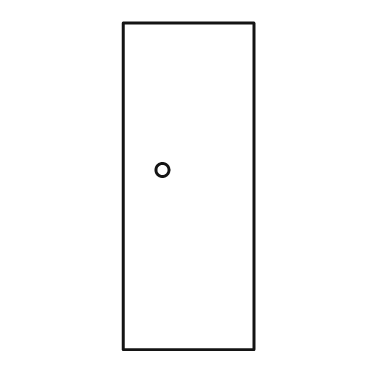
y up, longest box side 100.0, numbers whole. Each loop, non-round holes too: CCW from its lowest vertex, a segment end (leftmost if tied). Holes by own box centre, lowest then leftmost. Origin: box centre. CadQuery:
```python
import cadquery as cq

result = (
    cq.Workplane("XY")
    .moveTo(-20.0, -50.0)
    .lineTo(20.0, -50.0)
    .lineTo(20.0, 50.0)
    .lineTo(-20.0, 50.0)
    .close()
    .moveTo(-8.0, 5.0)
    .circle(2.0)
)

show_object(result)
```